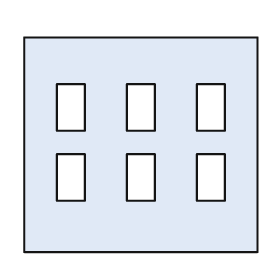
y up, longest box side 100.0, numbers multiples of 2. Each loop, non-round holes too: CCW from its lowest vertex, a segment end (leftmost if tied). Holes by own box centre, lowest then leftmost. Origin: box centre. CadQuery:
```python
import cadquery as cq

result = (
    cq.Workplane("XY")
    .moveTo(-50.0, -46.0)
    .lineTo(50.0, -46.0)
    .lineTo(50.0, 46.0)
    .lineTo(-50.0, 46.0)
    .close()
    .moveTo(-36.0, -24.0)
    .lineTo(-24.0, -24.0)
    .lineTo(-24.0, -4.0)
    .lineTo(-36.0, -4.0)
    .close()
    .moveTo(-6.0, -24.0)
    .lineTo(6.0, -24.0)
    .lineTo(6.0, -4.0)
    .lineTo(-6.0, -4.0)
    .close()
    .moveTo(24.0, -24.0)
    .lineTo(36.0, -24.0)
    .lineTo(36.0, -4.0)
    .lineTo(24.0, -4.0)
    .close()
    .moveTo(-36.0, 6.0)
    .lineTo(-24.0, 6.0)
    .lineTo(-24.0, 26.0)
    .lineTo(-36.0, 26.0)
    .close()
    .moveTo(-6.0, 6.0)
    .lineTo(6.0, 6.0)
    .lineTo(6.0, 26.0)
    .lineTo(-6.0, 26.0)
    .close()
    .moveTo(24.0, 6.0)
    .lineTo(36.0, 6.0)
    .lineTo(36.0, 26.0)
    .lineTo(24.0, 26.0)
    .close()
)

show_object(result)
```